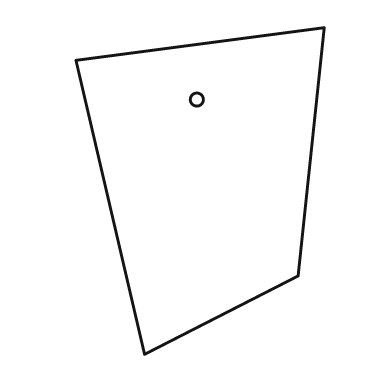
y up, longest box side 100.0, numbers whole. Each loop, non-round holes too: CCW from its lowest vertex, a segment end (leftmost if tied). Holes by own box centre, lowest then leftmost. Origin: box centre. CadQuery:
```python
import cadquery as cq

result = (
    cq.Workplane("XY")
    .moveTo(-17.0, -50.0)
    .lineTo(30.0, -26.0)
    .lineTo(38.0, 50.0)
    .lineTo(-38.0, 40.0)
    .close()
    .moveTo(-1.0, 28.0)
    .circle(2.0)
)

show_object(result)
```